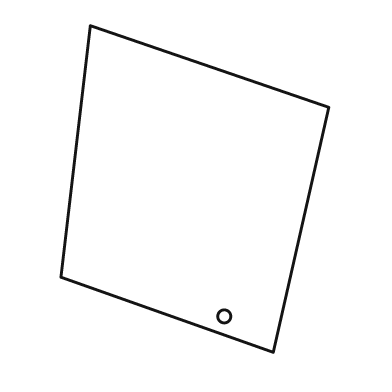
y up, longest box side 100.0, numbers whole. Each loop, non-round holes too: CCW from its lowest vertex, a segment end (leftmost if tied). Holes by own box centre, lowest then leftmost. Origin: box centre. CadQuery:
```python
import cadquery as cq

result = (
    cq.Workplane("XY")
    .moveTo(24.0, -50.0)
    .lineTo(41.0, 25.0)
    .lineTo(-32.0, 50.0)
    .lineTo(-41.0, -27.0)
    .close()
    .moveTo(9.0, -39.0)
    .circle(2.0)
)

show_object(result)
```